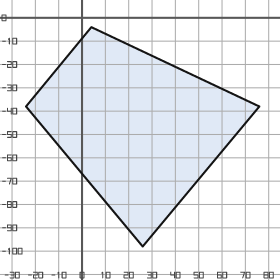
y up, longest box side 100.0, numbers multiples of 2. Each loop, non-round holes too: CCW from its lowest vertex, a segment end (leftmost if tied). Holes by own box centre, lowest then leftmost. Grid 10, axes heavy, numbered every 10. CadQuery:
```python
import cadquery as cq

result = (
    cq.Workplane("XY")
    .moveTo(26.0, -98.0)
    .lineTo(76.0, -38.0)
    .lineTo(4.0, -4.0)
    .lineTo(-24.0, -38.0)
    .close()
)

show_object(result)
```